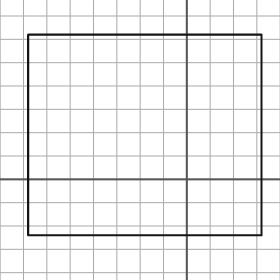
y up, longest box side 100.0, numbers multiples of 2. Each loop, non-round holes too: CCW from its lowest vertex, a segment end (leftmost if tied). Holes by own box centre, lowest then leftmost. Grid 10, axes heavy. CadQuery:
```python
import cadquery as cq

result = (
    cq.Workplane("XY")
    .moveTo(-68.0, -24.0)
    .lineTo(32.0, -24.0)
    .lineTo(32.0, 62.0)
    .lineTo(-68.0, 62.0)
    .close()
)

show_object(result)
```